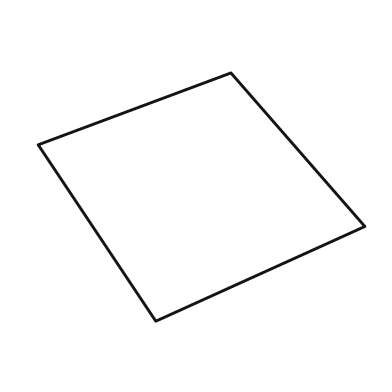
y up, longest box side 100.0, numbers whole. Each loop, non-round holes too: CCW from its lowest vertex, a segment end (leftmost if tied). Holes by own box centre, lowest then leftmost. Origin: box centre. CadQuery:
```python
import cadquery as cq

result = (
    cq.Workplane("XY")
    .moveTo(-14.0, -38.0)
    .lineTo(50.0, -9.0)
    .lineTo(9.0, 38.0)
    .lineTo(-50.0, 16.0)
    .close()
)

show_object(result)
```